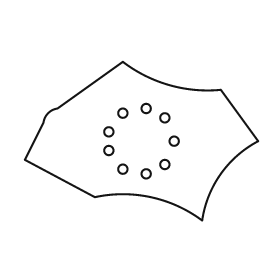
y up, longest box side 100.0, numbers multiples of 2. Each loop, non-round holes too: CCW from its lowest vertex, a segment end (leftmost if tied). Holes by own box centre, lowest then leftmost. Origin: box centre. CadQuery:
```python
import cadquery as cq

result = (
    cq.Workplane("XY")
    .moveTo(26.0, -34.0)
    .threePointArc((34.0, -14.0), (50.0, 0.0))
    .lineTo(34.0, 22.0)
    .threePointArc((12.0, 24.0), (-8.0, 34.0))
    .lineTo(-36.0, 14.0)
    .threePointArc((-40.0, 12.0), (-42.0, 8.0))
    .lineTo(-50.0, -8.0)
    .lineTo(-20.0, -24.0)
    .threePointArc((4.0, -24.0), (26.0, -34.0))
    .close()
    .moveTo(2.0, -14.0)
    .circle(2.0)
    .moveTo(-8.0, -12.0)
    .circle(2.0)
    .moveTo(10.0, -10.0)
    .circle(2.0)
    .moveTo(-14.0, -4.0)
    .circle(2.0)
    .moveTo(14.0, 0.0)
    .circle(2.0)
    .moveTo(-14.0, 4.0)
    .circle(2.0)
    .moveTo(10.0, 10.0)
    .circle(2.0)
    .moveTo(-8.0, 12.0)
    .circle(2.0)
    .moveTo(2.0, 14.0)
    .circle(2.0)
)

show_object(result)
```